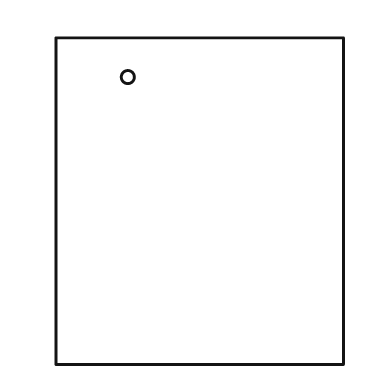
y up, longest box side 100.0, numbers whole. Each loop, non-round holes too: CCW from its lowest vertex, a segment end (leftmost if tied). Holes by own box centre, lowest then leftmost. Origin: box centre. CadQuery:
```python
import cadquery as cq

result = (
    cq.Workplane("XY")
    .moveTo(-44.0, -50.0)
    .lineTo(44.0, -50.0)
    .lineTo(44.0, 50.0)
    .lineTo(-44.0, 50.0)
    .close()
    .moveTo(-22.0, 38.0)
    .circle(2.0)
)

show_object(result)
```